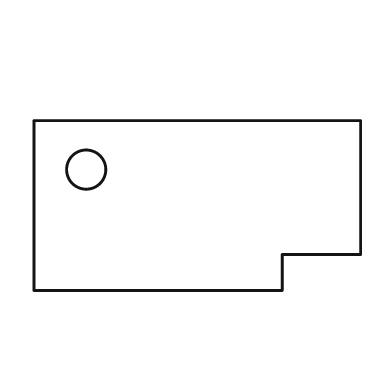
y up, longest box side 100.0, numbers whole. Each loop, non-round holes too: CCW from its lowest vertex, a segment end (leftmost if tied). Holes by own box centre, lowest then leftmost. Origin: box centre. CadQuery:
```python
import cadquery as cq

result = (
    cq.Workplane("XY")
    .moveTo(-50.0, -26.0)
    .lineTo(26.0, -26.0)
    .lineTo(26.0, -15.0)
    .lineTo(50.0, -15.0)
    .lineTo(50.0, 26.0)
    .lineTo(-50.0, 26.0)
    .close()
    .moveTo(-34.0, 11.0)
    .circle(6.0)
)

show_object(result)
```